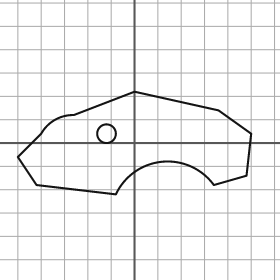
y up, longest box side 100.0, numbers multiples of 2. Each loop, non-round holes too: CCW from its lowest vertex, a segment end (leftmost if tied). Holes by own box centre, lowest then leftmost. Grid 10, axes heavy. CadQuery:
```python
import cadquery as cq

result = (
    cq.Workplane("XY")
    .moveTo(-8.0, -22.0)
    .threePointArc((12.0, -8.0), (34.0, -18.0))
    .lineTo(48.0, -14.0)
    .lineTo(50.0, 4.0)
    .lineTo(36.0, 14.0)
    .lineTo(0.0, 22.0)
    .lineTo(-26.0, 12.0)
    .threePointArc((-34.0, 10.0), (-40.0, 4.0))
    .lineTo(-50.0, -6.0)
    .lineTo(-42.0, -18.0)
    .close()
    .moveTo(-12.0, 4.0)
    .circle(4.0)
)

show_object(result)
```